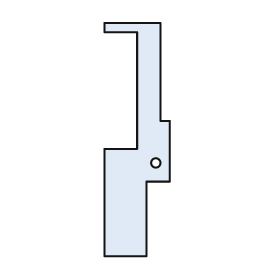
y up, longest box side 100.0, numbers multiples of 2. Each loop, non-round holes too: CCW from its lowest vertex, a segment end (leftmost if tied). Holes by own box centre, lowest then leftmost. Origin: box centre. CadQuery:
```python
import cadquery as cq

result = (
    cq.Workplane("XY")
    .moveTo(-14.0, -50.0)
    .lineTo(4.0, -50.0)
    .lineTo(4.0, -18.0)
    .lineTo(14.0, -18.0)
    .lineTo(14.0, 8.0)
    .lineTo(10.0, 8.0)
    .lineTo(10.0, 50.0)
    .lineTo(-14.0, 50.0)
    .lineTo(-14.0, 46.0)
    .lineTo(0.0, 46.0)
    .lineTo(0.0, -4.0)
    .lineTo(-14.0, -4.0)
    .close()
    .moveTo(8.0, -10.0)
    .circle(2.0)
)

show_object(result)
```